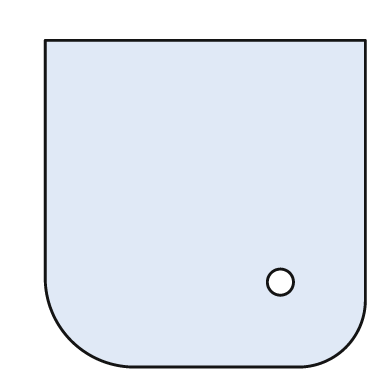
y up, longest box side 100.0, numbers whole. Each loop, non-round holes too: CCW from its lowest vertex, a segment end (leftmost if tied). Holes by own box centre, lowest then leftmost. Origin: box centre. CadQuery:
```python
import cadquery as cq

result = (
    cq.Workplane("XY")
    .moveTo(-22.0, -50.0)
    .lineTo(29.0, -50.0)
    .threePointArc((43.0, -44.0), (49.0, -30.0))
    .lineTo(49.0, 50.0)
    .lineTo(-49.0, 50.0)
    .lineTo(-49.0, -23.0)
    .threePointArc((-41.0, -42.0), (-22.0, -50.0))
    .close()
    .moveTo(23.0, -24.0)
    .circle(4.0)
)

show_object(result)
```